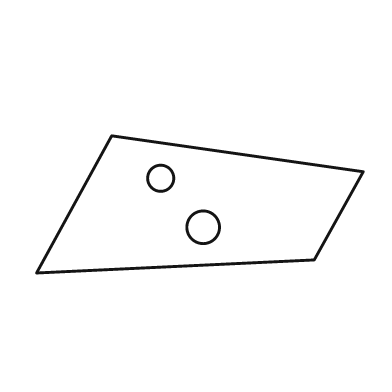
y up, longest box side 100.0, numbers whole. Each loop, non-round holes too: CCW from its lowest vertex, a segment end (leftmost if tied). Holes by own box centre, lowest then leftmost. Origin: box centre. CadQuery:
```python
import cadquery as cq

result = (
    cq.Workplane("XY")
    .moveTo(-50.0, -21.0)
    .lineTo(35.0, -17.0)
    .lineTo(50.0, 10.0)
    .lineTo(-27.0, 21.0)
    .close()
    .moveTo(1.0, -7.0)
    .circle(5.0)
    .moveTo(-12.0, 8.0)
    .circle(4.0)
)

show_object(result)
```